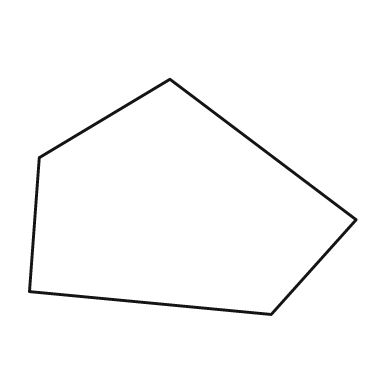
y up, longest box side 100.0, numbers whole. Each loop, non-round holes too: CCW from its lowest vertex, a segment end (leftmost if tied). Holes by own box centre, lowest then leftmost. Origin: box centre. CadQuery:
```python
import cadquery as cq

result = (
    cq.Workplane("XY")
    .moveTo(24.0, -36.0)
    .lineTo(50.0, -7.0)
    .lineTo(-7.0, 36.0)
    .lineTo(-47.0, 12.0)
    .lineTo(-50.0, -29.0)
    .close()
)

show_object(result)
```